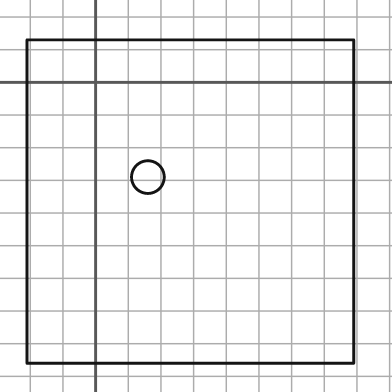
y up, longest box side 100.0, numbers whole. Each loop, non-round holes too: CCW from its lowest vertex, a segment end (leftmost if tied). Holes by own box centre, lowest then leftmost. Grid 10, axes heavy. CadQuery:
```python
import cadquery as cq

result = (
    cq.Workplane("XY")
    .moveTo(-21.0, -86.0)
    .lineTo(79.0, -86.0)
    .lineTo(79.0, 13.0)
    .lineTo(-21.0, 13.0)
    .close()
    .moveTo(16.0, -29.0)
    .circle(5.0)
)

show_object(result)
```